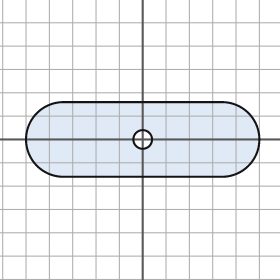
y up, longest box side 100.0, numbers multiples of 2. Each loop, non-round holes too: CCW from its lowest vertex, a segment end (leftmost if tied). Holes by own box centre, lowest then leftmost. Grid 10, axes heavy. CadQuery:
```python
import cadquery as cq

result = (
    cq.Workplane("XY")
    .moveTo(-34.0, -16.0)
    .lineTo(34.0, -16.0)
    .threePointArc((50.0, 0.0), (34.0, 16.0))
    .lineTo(-34.0, 16.0)
    .threePointArc((-50.0, 0.0), (-34.0, -16.0))
    .close()
    .moveTo(0.0, 0.0)
    .circle(4.0)
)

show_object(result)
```